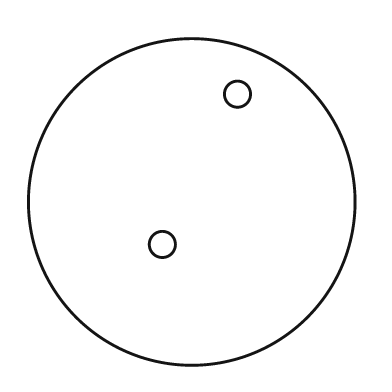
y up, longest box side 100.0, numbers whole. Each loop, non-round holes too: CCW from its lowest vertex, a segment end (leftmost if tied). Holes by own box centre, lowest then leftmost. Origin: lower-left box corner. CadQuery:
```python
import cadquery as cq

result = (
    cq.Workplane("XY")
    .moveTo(50.0, 50.0)
    .circle(50.0)
    .moveTo(41.0, 37.0)
    .circle(4.0)
    .moveTo(64.0, 83.0)
    .circle(4.0)
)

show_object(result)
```